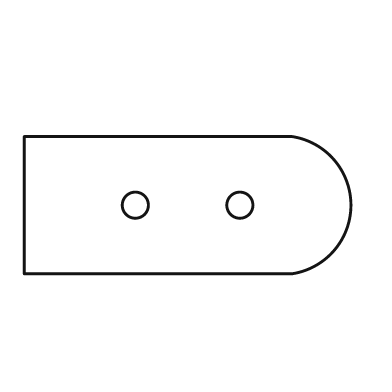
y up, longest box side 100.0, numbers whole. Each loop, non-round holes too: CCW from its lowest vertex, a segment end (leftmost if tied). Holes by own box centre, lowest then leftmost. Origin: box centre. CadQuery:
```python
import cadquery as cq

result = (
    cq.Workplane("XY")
    .moveTo(-50.0, -21.0)
    .lineTo(32.0, -21.0)
    .threePointArc((50.0, 0.0), (32.0, 21.0))
    .lineTo(-50.0, 21.0)
    .close()
    .moveTo(-16.0, 0.0)
    .circle(4.0)
    .moveTo(16.0, 0.0)
    .circle(4.0)
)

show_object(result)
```